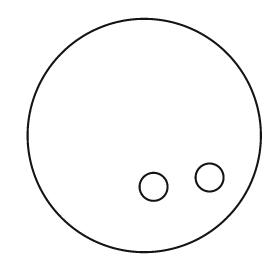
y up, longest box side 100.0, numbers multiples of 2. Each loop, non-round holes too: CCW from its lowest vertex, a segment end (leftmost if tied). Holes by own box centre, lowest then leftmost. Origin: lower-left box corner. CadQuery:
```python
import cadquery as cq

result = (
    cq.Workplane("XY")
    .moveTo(50.0, 50.0)
    .circle(50.0)
    .moveTo(54.0, 28.0)
    .circle(6.0)
    .moveTo(78.0, 32.0)
    .circle(6.0)
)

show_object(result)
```